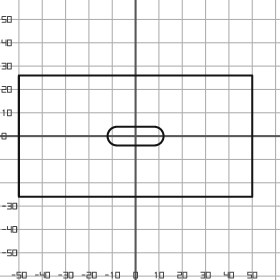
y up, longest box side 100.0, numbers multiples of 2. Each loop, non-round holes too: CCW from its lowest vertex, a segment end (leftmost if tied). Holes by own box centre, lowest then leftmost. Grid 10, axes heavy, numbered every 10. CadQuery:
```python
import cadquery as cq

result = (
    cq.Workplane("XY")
    .moveTo(-50.0, -26.0)
    .lineTo(50.0, -26.0)
    .lineTo(50.0, 26.0)
    .lineTo(-50.0, 26.0)
    .close()
    .moveTo(-8.0, -4.0)
    .lineTo(8.0, -4.0)
    .threePointArc((12.0, 0.0), (8.0, 4.0))
    .lineTo(-8.0, 4.0)
    .threePointArc((-12.0, 0.0), (-8.0, -4.0))
    .close()
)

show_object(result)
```